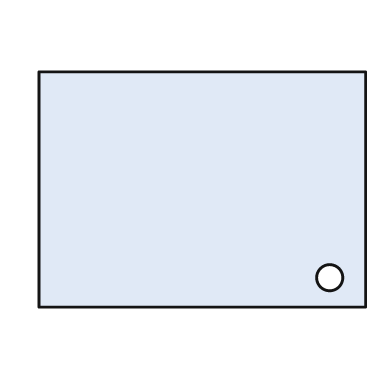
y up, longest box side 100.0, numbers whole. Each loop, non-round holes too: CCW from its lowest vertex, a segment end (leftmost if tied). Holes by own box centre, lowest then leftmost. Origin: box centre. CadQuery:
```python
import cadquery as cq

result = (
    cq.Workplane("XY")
    .moveTo(-50.0, -36.0)
    .lineTo(50.0, -36.0)
    .lineTo(50.0, 36.0)
    .lineTo(-50.0, 36.0)
    .close()
    .moveTo(39.0, -27.0)
    .circle(4.0)
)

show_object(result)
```